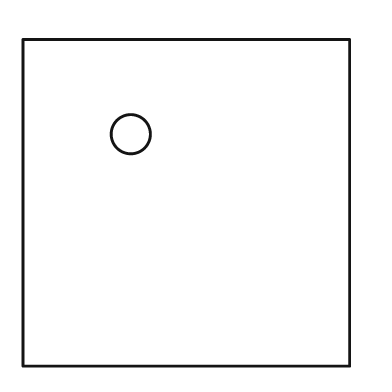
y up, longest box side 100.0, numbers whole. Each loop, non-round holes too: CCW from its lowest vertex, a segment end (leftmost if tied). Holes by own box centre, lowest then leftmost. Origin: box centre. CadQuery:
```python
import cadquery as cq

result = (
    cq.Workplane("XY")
    .moveTo(-50.0, -50.0)
    .lineTo(50.0, -50.0)
    .lineTo(50.0, 50.0)
    .lineTo(-50.0, 50.0)
    .close()
    .moveTo(-17.0, 21.0)
    .circle(6.0)
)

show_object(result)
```